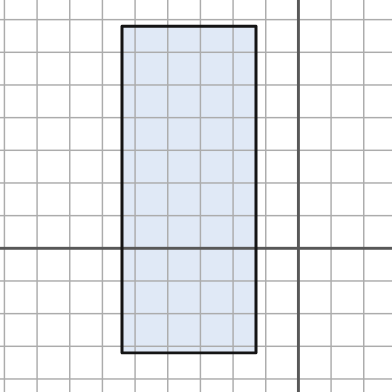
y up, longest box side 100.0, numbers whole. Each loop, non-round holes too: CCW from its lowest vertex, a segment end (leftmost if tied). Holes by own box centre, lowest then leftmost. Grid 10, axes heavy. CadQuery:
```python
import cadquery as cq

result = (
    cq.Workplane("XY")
    .moveTo(-54.0, -32.0)
    .lineTo(-13.0, -32.0)
    .lineTo(-13.0, 68.0)
    .lineTo(-54.0, 68.0)
    .close()
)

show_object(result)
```